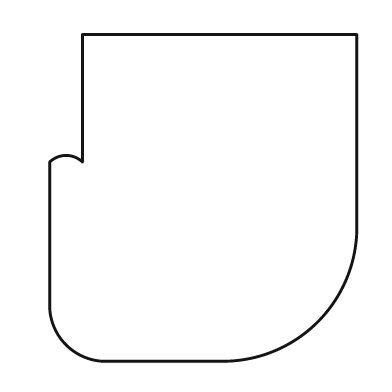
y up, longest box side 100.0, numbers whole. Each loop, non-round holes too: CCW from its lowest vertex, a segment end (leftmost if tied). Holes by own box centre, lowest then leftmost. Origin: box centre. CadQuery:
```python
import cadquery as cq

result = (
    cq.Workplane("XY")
    .moveTo(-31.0, -50.0)
    .lineTo(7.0, -50.0)
    .threePointArc((35.0, -38.0), (47.0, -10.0))
    .lineTo(47.0, 50.0)
    .lineTo(-37.0, 50.0)
    .lineTo(-37.0, 11.0)
    .threePointArc((-42.0, 13.0), (-47.0, 11.0))
    .lineTo(-47.0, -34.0)
    .threePointArc((-42.0, -45.0), (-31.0, -50.0))
    .close()
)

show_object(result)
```